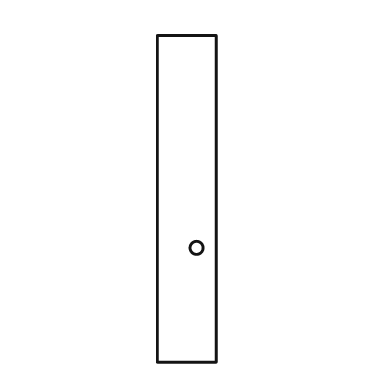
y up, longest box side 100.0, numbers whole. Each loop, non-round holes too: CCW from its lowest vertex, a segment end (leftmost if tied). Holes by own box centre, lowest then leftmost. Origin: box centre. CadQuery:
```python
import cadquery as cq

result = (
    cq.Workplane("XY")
    .moveTo(-9.0, -50.0)
    .lineTo(9.0, -50.0)
    .lineTo(9.0, 50.0)
    .lineTo(-9.0, 50.0)
    .close()
    .moveTo(3.0, -15.0)
    .circle(2.0)
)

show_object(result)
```